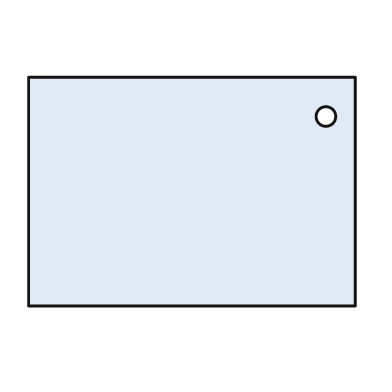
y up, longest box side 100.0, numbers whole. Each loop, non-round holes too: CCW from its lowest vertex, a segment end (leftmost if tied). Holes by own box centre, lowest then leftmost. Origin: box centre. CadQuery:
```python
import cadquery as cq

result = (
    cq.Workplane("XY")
    .moveTo(-50.0, -35.0)
    .lineTo(50.0, -35.0)
    .lineTo(50.0, 35.0)
    .lineTo(-50.0, 35.0)
    .close()
    .moveTo(41.0, 23.0)
    .circle(3.0)
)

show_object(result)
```